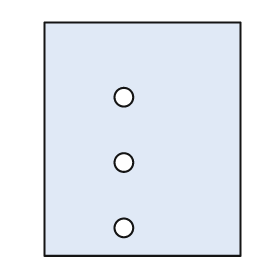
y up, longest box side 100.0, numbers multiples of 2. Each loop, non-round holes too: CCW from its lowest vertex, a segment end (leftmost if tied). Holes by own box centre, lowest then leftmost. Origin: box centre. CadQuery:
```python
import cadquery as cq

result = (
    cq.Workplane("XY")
    .moveTo(-42.0, -50.0)
    .lineTo(42.0, -50.0)
    .lineTo(42.0, 50.0)
    .lineTo(-42.0, 50.0)
    .close()
    .moveTo(-8.0, -38.0)
    .circle(4.0)
    .moveTo(-8.0, -10.0)
    .circle(4.0)
    .moveTo(-8.0, 18.0)
    .circle(4.0)
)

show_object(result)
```